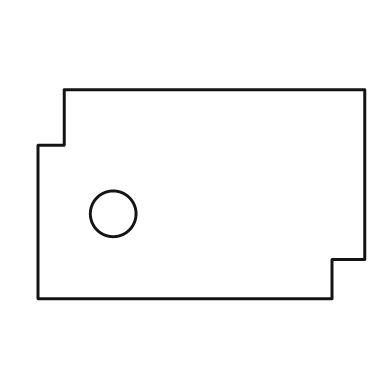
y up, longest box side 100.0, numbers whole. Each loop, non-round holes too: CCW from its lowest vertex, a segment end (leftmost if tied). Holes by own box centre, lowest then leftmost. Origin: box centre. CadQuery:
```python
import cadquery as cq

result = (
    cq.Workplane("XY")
    .moveTo(-50.0, -32.0)
    .lineTo(40.0, -32.0)
    .lineTo(40.0, -20.0)
    .lineTo(50.0, -20.0)
    .lineTo(50.0, 32.0)
    .lineTo(-42.0, 32.0)
    .lineTo(-42.0, 15.0)
    .lineTo(-50.0, 15.0)
    .close()
    .moveTo(-27.0, -6.0)
    .circle(7.0)
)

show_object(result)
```